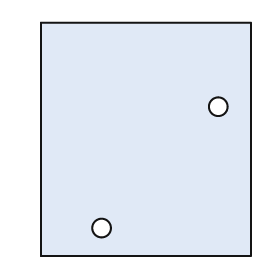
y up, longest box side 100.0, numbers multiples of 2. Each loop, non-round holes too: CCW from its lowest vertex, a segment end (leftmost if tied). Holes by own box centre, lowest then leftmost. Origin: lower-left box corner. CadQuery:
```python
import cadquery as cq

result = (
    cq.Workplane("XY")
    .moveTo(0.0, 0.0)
    .lineTo(90.0, 0.0)
    .lineTo(90.0, 100.0)
    .lineTo(0.0, 100.0)
    .close()
    .moveTo(26.0, 12.0)
    .circle(4.0)
    .moveTo(76.0, 64.0)
    .circle(4.0)
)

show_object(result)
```